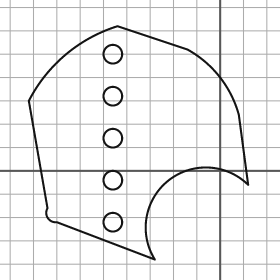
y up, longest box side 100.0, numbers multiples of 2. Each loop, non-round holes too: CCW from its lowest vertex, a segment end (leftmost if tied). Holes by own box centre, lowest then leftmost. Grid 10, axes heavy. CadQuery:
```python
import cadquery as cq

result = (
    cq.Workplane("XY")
    .moveTo(-28.0, -38.0)
    .threePointArc((-22.0, -4.0), (12.0, -6.0))
    .lineTo(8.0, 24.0)
    .threePointArc((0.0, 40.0), (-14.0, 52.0))
    .lineTo(-44.0, 62.0)
    .threePointArc((-66.0, 50.0), (-82.0, 30.0))
    .lineTo(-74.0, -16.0)
    .threePointArc((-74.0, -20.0), (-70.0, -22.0))
    .close()
    .moveTo(-46.0, -22.0)
    .circle(4.0)
    .moveTo(-46.0, -4.0)
    .circle(4.0)
    .moveTo(-46.0, 14.0)
    .circle(4.0)
    .moveTo(-46.0, 32.0)
    .circle(4.0)
    .moveTo(-46.0, 50.0)
    .circle(4.0)
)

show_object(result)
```